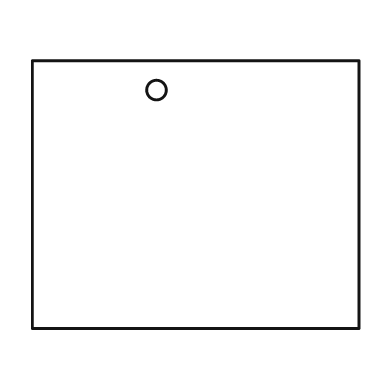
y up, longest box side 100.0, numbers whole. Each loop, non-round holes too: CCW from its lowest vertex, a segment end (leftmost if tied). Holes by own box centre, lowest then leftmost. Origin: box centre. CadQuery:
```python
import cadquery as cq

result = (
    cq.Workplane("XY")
    .moveTo(-50.0, -41.0)
    .lineTo(50.0, -41.0)
    .lineTo(50.0, 41.0)
    .lineTo(-50.0, 41.0)
    .close()
    .moveTo(-12.0, 32.0)
    .circle(3.0)
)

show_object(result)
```